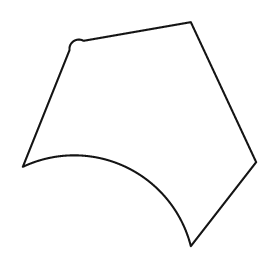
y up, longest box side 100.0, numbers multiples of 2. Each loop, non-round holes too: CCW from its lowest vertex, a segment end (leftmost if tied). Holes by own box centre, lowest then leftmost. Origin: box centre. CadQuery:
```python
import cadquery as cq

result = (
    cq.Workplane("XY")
    .moveTo(22.0, -48.0)
    .lineTo(50.0, -12.0)
    .lineTo(22.0, 48.0)
    .lineTo(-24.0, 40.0)
    .threePointArc((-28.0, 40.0), (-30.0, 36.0))
    .lineTo(-50.0, -14.0)
    .threePointArc((-6.0, -14.0), (22.0, -48.0))
    .close()
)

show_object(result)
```